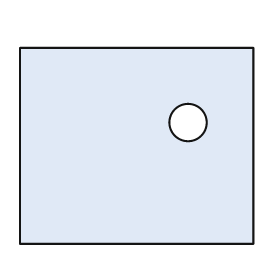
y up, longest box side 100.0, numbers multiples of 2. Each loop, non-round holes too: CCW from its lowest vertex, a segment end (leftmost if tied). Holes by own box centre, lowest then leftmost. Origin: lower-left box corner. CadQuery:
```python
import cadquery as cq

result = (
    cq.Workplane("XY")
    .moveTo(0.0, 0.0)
    .lineTo(100.0, 0.0)
    .lineTo(100.0, 84.0)
    .lineTo(0.0, 84.0)
    .close()
    .moveTo(72.0, 52.0)
    .circle(8.0)
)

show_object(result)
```